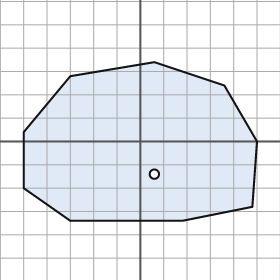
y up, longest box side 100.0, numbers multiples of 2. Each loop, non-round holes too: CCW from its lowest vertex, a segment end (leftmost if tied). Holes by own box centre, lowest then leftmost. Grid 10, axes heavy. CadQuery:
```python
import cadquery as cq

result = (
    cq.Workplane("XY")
    .moveTo(-30.0, -34.0)
    .lineTo(18.0, -34.0)
    .lineTo(48.0, -28.0)
    .lineTo(50.0, 0.0)
    .lineTo(36.0, 24.0)
    .lineTo(6.0, 34.0)
    .lineTo(-30.0, 28.0)
    .lineTo(-50.0, 4.0)
    .lineTo(-50.0, -20.0)
    .close()
    .moveTo(6.0, -14.0)
    .circle(2.0)
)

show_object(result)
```